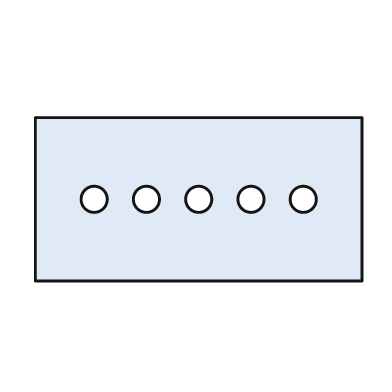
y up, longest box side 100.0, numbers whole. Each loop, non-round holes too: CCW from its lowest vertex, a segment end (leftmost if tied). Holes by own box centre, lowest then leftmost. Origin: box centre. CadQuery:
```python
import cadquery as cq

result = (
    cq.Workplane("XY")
    .moveTo(-50.0, -25.0)
    .lineTo(50.0, -25.0)
    .lineTo(50.0, 25.0)
    .lineTo(-50.0, 25.0)
    .close()
    .moveTo(-32.0, 0.0)
    .circle(4.0)
    .moveTo(-16.0, 0.0)
    .circle(4.0)
    .moveTo(0.0, 0.0)
    .circle(4.0)
    .moveTo(16.0, 0.0)
    .circle(4.0)
    .moveTo(32.0, 0.0)
    .circle(4.0)
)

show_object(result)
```